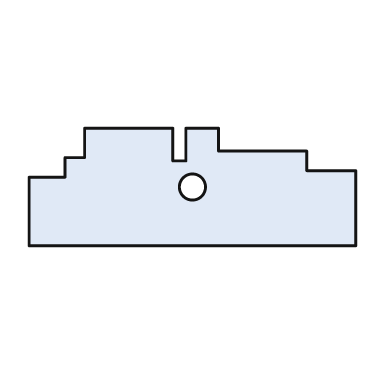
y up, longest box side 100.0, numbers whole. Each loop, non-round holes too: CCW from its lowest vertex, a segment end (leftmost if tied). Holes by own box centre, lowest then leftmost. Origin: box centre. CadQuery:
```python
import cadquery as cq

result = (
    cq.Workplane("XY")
    .moveTo(-50.0, -18.0)
    .lineTo(50.0, -18.0)
    .lineTo(50.0, 5.0)
    .lineTo(35.0, 5.0)
    .lineTo(35.0, 11.0)
    .lineTo(8.0, 11.0)
    .lineTo(8.0, 18.0)
    .lineTo(-2.0, 18.0)
    .lineTo(-2.0, 8.0)
    .lineTo(-6.0, 8.0)
    .lineTo(-6.0, 18.0)
    .lineTo(-33.0, 18.0)
    .lineTo(-33.0, 9.0)
    .lineTo(-39.0, 9.0)
    .lineTo(-39.0, 3.0)
    .lineTo(-50.0, 3.0)
    .close()
    .moveTo(0.0, 0.0)
    .circle(4.0)
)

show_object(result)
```